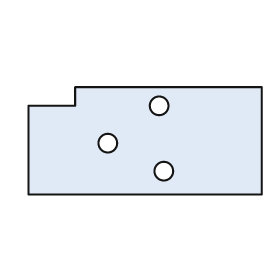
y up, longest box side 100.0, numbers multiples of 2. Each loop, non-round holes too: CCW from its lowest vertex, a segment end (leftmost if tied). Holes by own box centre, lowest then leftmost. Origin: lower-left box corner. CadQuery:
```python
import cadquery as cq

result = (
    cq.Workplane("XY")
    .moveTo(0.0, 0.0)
    .lineTo(100.0, 0.0)
    .lineTo(100.0, 46.0)
    .lineTo(20.0, 46.0)
    .lineTo(20.0, 38.0)
    .lineTo(0.0, 38.0)
    .close()
    .moveTo(58.0, 10.0)
    .circle(4.0)
    .moveTo(34.0, 22.0)
    .circle(4.0)
    .moveTo(56.0, 38.0)
    .circle(4.0)
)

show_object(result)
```